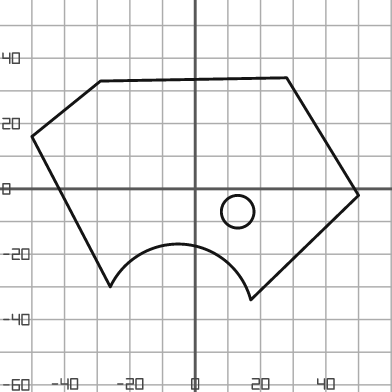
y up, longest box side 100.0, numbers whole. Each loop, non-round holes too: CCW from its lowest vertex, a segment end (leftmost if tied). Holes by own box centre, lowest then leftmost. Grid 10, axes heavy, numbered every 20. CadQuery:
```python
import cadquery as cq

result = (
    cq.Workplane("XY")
    .moveTo(17.0, -34.0)
    .lineTo(50.0, -2.0)
    .lineTo(28.0, 34.0)
    .lineTo(-29.0, 33.0)
    .lineTo(-50.0, 16.0)
    .lineTo(-26.0, -30.0)
    .threePointArc((-3.0, -17.0), (17.0, -34.0))
    .close()
    .moveTo(13.0, -7.0)
    .circle(5.0)
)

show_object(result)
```